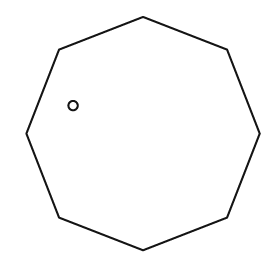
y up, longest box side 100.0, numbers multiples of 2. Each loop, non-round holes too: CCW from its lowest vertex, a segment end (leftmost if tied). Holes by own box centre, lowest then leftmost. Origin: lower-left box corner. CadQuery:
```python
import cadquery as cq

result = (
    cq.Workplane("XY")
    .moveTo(50.0, 0.0)
    .lineTo(86.0, 14.0)
    .lineTo(100.0, 50.0)
    .lineTo(86.0, 86.0)
    .lineTo(50.0, 100.0)
    .lineTo(14.0, 86.0)
    .lineTo(0.0, 50.0)
    .lineTo(14.0, 14.0)
    .close()
    .moveTo(20.0, 62.0)
    .circle(2.0)
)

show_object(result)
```